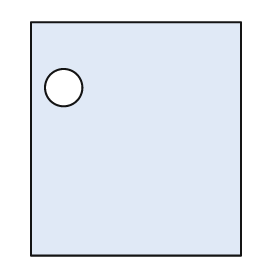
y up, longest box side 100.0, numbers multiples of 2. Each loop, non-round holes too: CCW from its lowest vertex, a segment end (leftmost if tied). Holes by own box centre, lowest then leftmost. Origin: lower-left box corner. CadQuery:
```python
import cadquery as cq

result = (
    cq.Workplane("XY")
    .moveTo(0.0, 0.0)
    .lineTo(90.0, 0.0)
    .lineTo(90.0, 100.0)
    .lineTo(0.0, 100.0)
    .close()
    .moveTo(14.0, 72.0)
    .circle(8.0)
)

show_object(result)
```